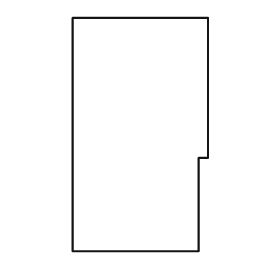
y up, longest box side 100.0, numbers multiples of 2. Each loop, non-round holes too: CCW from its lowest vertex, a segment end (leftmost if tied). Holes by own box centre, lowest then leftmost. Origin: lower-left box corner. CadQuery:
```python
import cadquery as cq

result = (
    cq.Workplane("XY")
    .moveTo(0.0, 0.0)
    .lineTo(54.0, 0.0)
    .lineTo(54.0, 40.0)
    .lineTo(58.0, 40.0)
    .lineTo(58.0, 100.0)
    .lineTo(0.0, 100.0)
    .close()
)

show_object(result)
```